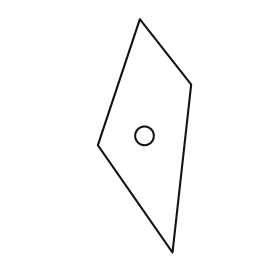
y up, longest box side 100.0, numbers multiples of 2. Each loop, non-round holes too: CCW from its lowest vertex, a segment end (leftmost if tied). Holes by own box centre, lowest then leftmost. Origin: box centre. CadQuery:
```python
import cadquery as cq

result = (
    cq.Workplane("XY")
    .moveTo(12.0, -50.0)
    .lineTo(20.0, 22.0)
    .lineTo(-2.0, 50.0)
    .lineTo(-20.0, -4.0)
    .close()
    .moveTo(0.0, 0.0)
    .circle(4.0)
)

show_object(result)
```